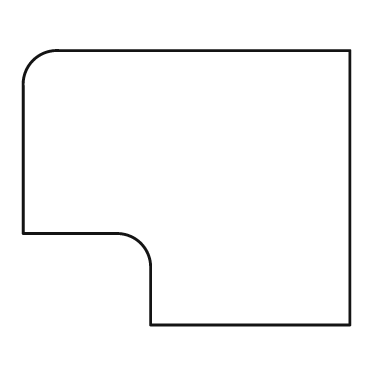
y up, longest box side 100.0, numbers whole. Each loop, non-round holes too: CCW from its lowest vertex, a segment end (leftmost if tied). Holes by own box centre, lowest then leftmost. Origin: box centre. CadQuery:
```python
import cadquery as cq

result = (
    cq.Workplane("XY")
    .moveTo(-11.0, -42.0)
    .lineTo(50.0, -42.0)
    .lineTo(50.0, 42.0)
    .lineTo(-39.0, 42.0)
    .threePointArc((-47.0, 39.0), (-50.0, 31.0))
    .lineTo(-50.0, -14.0)
    .lineTo(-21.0, -14.0)
    .threePointArc((-14.0, -17.0), (-11.0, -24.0))
    .close()
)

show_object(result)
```